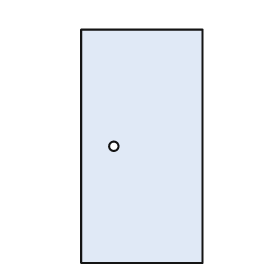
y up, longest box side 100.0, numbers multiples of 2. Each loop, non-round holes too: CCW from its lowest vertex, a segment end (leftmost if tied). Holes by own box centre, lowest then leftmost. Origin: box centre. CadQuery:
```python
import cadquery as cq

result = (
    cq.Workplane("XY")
    .moveTo(-26.0, -50.0)
    .lineTo(26.0, -50.0)
    .lineTo(26.0, 50.0)
    .lineTo(-26.0, 50.0)
    .close()
    .moveTo(-12.0, 0.0)
    .circle(2.0)
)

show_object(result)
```